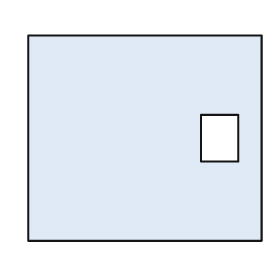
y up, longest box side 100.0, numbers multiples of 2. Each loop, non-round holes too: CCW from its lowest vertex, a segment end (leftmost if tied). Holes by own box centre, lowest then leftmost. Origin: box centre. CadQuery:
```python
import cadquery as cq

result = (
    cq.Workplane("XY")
    .moveTo(-50.0, -44.0)
    .lineTo(50.0, -44.0)
    .lineTo(50.0, 44.0)
    .lineTo(-50.0, 44.0)
    .close()
    .moveTo(24.0, -10.0)
    .lineTo(40.0, -10.0)
    .lineTo(40.0, 10.0)
    .lineTo(24.0, 10.0)
    .close()
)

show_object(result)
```